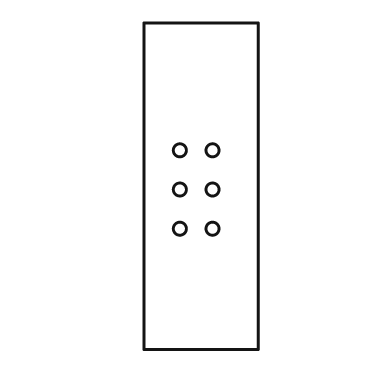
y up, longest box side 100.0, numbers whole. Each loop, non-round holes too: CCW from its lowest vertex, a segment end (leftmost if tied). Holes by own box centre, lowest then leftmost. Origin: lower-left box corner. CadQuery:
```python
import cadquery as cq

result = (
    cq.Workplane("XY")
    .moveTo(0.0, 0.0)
    .lineTo(35.0, 0.0)
    .lineTo(35.0, 100.0)
    .lineTo(0.0, 100.0)
    .close()
    .moveTo(11.0, 37.0)
    .circle(2.0)
    .moveTo(21.0, 37.0)
    .circle(2.0)
    .moveTo(11.0, 49.0)
    .circle(2.0)
    .moveTo(21.0, 49.0)
    .circle(2.0)
    .moveTo(11.0, 61.0)
    .circle(2.0)
    .moveTo(21.0, 61.0)
    .circle(2.0)
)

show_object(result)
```